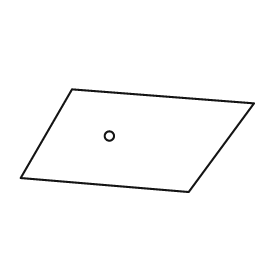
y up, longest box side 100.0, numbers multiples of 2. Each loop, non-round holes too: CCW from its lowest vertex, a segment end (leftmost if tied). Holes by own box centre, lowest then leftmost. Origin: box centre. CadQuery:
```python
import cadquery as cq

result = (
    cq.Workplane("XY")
    .moveTo(22.0, -22.0)
    .lineTo(50.0, 16.0)
    .lineTo(-28.0, 22.0)
    .lineTo(-50.0, -16.0)
    .close()
    .moveTo(-12.0, 2.0)
    .circle(2.0)
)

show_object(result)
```